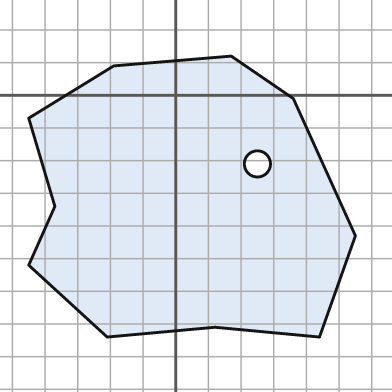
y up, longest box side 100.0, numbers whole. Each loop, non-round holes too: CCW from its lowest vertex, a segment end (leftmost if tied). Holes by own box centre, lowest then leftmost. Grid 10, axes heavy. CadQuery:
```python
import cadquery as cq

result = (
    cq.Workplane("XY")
    .moveTo(-21.0, -74.0)
    .lineTo(12.0, -71.0)
    .lineTo(44.0, -74.0)
    .lineTo(55.0, -43.0)
    .lineTo(36.0, -1.0)
    .lineTo(17.0, 12.0)
    .lineTo(-19.0, 9.0)
    .lineTo(-45.0, -7.0)
    .lineTo(-37.0, -34.0)
    .lineTo(-45.0, -52.0)
    .close()
    .moveTo(25.0, -21.0)
    .circle(4.0)
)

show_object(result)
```